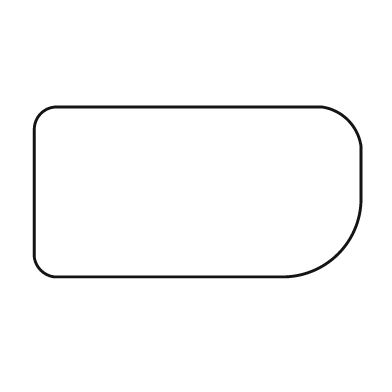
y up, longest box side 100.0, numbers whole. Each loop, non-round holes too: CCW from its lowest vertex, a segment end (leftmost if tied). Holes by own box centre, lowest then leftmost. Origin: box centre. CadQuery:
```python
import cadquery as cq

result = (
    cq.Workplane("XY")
    .moveTo(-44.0, -26.0)
    .lineTo(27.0, -26.0)
    .threePointArc((43.0, -19.0), (50.0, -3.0))
    .lineTo(50.0, 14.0)
    .threePointArc((46.0, 22.0), (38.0, 26.0))
    .lineTo(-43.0, 26.0)
    .threePointArc((-48.0, 24.0), (-50.0, 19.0))
    .lineTo(-50.0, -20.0)
    .threePointArc((-48.0, -24.0), (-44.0, -26.0))
    .close()
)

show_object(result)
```